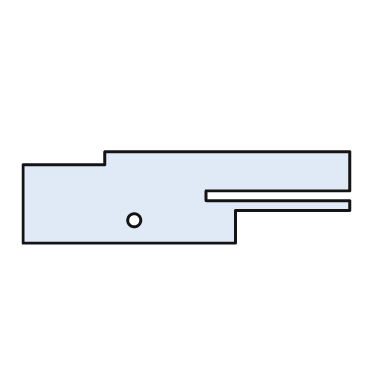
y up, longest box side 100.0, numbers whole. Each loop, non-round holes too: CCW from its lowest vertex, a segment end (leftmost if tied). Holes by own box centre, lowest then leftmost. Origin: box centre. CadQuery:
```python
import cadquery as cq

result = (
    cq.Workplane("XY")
    .moveTo(-50.0, -14.0)
    .lineTo(15.0, -14.0)
    .lineTo(15.0, -4.0)
    .lineTo(50.0, -4.0)
    .lineTo(50.0, -1.0)
    .lineTo(6.0, -1.0)
    .lineTo(6.0, 2.0)
    .lineTo(50.0, 2.0)
    .lineTo(50.0, 14.0)
    .lineTo(-25.0, 14.0)
    .lineTo(-25.0, 10.0)
    .lineTo(-50.0, 10.0)
    .close()
    .moveTo(-16.0, -7.0)
    .circle(2.0)
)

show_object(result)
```